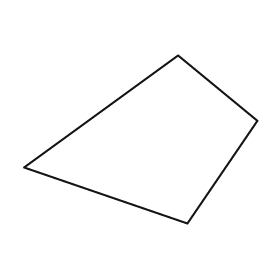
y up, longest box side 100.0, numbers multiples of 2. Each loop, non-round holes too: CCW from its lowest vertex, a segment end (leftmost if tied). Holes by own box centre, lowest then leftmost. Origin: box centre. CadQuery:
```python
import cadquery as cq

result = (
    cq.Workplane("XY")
    .moveTo(20.0, -36.0)
    .lineTo(50.0, 8.0)
    .lineTo(16.0, 36.0)
    .lineTo(-50.0, -12.0)
    .close()
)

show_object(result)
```